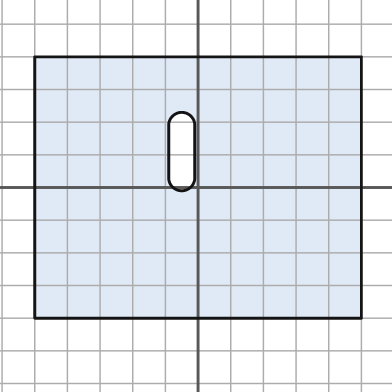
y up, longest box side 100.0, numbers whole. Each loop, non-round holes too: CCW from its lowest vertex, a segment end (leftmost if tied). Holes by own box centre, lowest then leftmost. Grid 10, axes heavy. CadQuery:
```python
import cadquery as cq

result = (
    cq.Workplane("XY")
    .moveTo(-50.0, -40.0)
    .lineTo(50.0, -40.0)
    .lineTo(50.0, 40.0)
    .lineTo(-50.0, 40.0)
    .close()
    .moveTo(-9.0, 3.0)
    .threePointArc((-5.0, -1.0), (-1.0, 3.0))
    .lineTo(-1.0, 19.0)
    .threePointArc((-5.0, 23.0), (-9.0, 19.0))
    .close()
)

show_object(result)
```